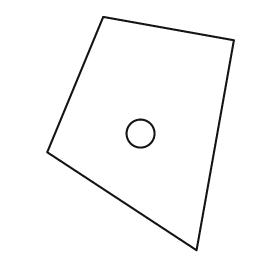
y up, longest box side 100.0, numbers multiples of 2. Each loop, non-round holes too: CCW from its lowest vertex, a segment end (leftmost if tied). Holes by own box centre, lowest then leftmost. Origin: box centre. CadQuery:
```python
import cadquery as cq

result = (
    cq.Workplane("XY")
    .moveTo(24.0, -50.0)
    .lineTo(40.0, 40.0)
    .lineTo(-16.0, 50.0)
    .lineTo(-40.0, -8.0)
    .close()
    .moveTo(0.0, 0.0)
    .circle(6.0)
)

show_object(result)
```